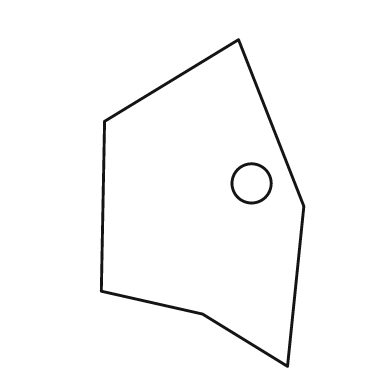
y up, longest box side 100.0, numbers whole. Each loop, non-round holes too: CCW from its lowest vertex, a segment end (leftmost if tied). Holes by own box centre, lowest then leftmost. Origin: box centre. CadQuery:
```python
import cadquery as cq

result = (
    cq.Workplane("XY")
    .moveTo(26.0, -50.0)
    .lineTo(31.0, -1.0)
    .lineTo(11.0, 50.0)
    .lineTo(-30.0, 25.0)
    .lineTo(-31.0, -27.0)
    .lineTo(0.0, -34.0)
    .close()
    .moveTo(15.0, 6.0)
    .circle(6.0)
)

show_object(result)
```